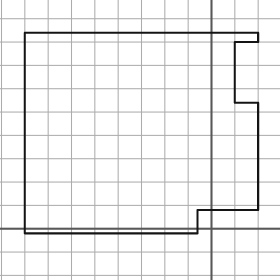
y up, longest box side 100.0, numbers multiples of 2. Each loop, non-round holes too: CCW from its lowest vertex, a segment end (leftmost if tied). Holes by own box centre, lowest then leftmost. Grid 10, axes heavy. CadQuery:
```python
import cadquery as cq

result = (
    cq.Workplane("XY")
    .moveTo(-80.0, -2.0)
    .lineTo(-6.0, -2.0)
    .lineTo(-6.0, 8.0)
    .lineTo(20.0, 8.0)
    .lineTo(20.0, 54.0)
    .lineTo(10.0, 54.0)
    .lineTo(10.0, 80.0)
    .lineTo(20.0, 80.0)
    .lineTo(20.0, 84.0)
    .lineTo(-80.0, 84.0)
    .close()
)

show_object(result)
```